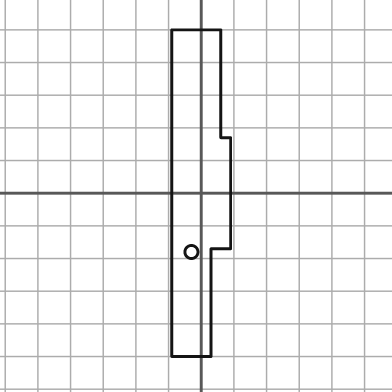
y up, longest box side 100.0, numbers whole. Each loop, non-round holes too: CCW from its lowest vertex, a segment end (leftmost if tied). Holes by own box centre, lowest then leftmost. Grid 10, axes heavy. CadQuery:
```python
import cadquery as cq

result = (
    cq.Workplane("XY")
    .moveTo(-9.0, -50.0)
    .lineTo(3.0, -50.0)
    .lineTo(3.0, -17.0)
    .lineTo(9.0, -17.0)
    .lineTo(9.0, 17.0)
    .lineTo(6.0, 17.0)
    .lineTo(6.0, 50.0)
    .lineTo(-9.0, 50.0)
    .close()
    .moveTo(-3.0, -18.0)
    .circle(2.0)
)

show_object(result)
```